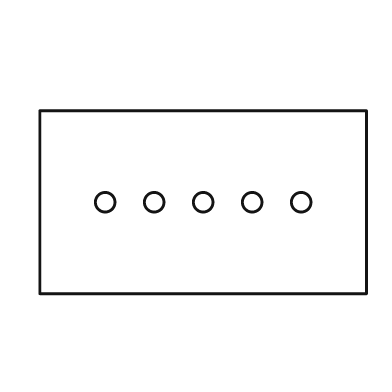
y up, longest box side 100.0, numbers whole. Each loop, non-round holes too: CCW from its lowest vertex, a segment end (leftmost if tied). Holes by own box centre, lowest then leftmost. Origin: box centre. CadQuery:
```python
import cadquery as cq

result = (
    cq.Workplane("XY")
    .moveTo(-50.0, -28.0)
    .lineTo(50.0, -28.0)
    .lineTo(50.0, 28.0)
    .lineTo(-50.0, 28.0)
    .close()
    .moveTo(-30.0, 0.0)
    .circle(3.0)
    .moveTo(-15.0, 0.0)
    .circle(3.0)
    .moveTo(0.0, 0.0)
    .circle(3.0)
    .moveTo(15.0, 0.0)
    .circle(3.0)
    .moveTo(30.0, 0.0)
    .circle(3.0)
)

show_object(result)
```